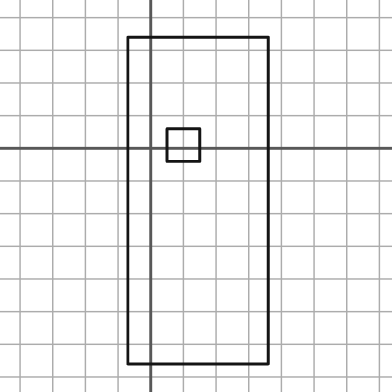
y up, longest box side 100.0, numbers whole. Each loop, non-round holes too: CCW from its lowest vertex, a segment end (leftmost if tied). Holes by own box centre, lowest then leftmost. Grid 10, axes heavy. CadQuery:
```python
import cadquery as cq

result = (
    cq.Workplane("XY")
    .moveTo(-7.0, -66.0)
    .lineTo(36.0, -66.0)
    .lineTo(36.0, 34.0)
    .lineTo(-7.0, 34.0)
    .close()
    .moveTo(5.0, -4.0)
    .lineTo(15.0, -4.0)
    .lineTo(15.0, 6.0)
    .lineTo(5.0, 6.0)
    .close()
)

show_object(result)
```